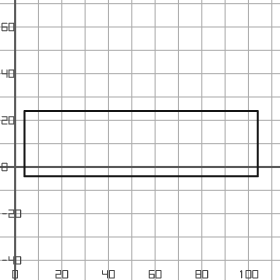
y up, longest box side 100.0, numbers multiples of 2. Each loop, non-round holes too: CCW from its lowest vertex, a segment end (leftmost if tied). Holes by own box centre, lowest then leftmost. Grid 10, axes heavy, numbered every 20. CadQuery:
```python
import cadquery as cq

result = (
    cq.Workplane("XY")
    .moveTo(4.0, -4.0)
    .lineTo(104.0, -4.0)
    .lineTo(104.0, 24.0)
    .lineTo(4.0, 24.0)
    .close()
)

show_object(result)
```